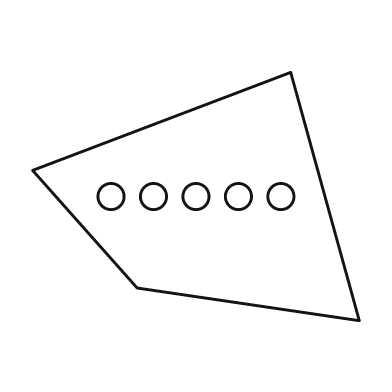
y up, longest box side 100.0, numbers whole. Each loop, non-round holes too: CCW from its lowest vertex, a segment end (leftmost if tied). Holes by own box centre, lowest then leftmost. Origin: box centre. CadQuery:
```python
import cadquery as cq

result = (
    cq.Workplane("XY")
    .moveTo(50.0, -38.0)
    .lineTo(29.0, 38.0)
    .lineTo(-50.0, 8.0)
    .lineTo(-18.0, -28.0)
    .close()
    .moveTo(-26.0, 0.0)
    .circle(4.0)
    .moveTo(-13.0, 0.0)
    .circle(4.0)
    .moveTo(0.0, 0.0)
    .circle(4.0)
    .moveTo(13.0, 0.0)
    .circle(4.0)
    .moveTo(26.0, 0.0)
    .circle(4.0)
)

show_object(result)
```